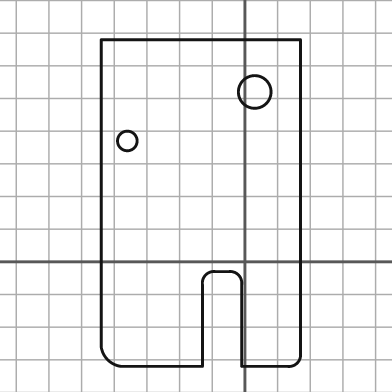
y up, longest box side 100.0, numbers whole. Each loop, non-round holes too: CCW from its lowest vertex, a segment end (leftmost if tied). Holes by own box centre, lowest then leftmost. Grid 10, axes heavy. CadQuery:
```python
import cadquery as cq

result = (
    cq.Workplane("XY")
    .moveTo(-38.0, -32.0)
    .lineTo(-13.0, -32.0)
    .lineTo(-13.0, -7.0)
    .threePointArc((-12.0, -4.0), (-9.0, -3.0))
    .lineTo(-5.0, -3.0)
    .threePointArc((-2.0, -4.0), (-1.0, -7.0))
    .lineTo(-1.0, -32.0)
    .lineTo(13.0, -32.0)
    .threePointArc((16.0, -31.0), (17.0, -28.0))
    .lineTo(17.0, 68.0)
    .lineTo(-44.0, 68.0)
    .lineTo(-44.0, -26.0)
    .threePointArc((-42.0, -30.0), (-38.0, -32.0))
    .close()
    .moveTo(-36.0, 37.0)
    .circle(3.0)
    .moveTo(3.0, 52.0)
    .circle(5.0)
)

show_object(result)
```